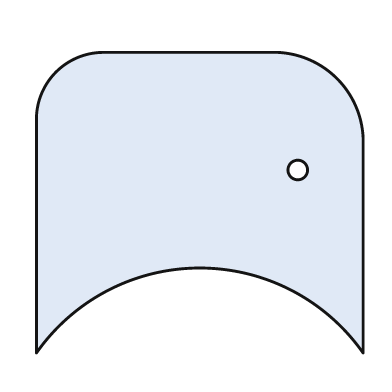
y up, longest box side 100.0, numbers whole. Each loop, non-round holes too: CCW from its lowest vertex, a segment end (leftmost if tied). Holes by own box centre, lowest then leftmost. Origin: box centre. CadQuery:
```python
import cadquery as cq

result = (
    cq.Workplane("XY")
    .moveTo(-50.0, -46.0)
    .threePointArc((0.0, -20.0), (50.0, -46.0))
    .lineTo(50.0, 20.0)
    .threePointArc((42.0, 38.0), (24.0, 46.0))
    .lineTo(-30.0, 46.0)
    .threePointArc((-44.0, 40.0), (-50.0, 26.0))
    .close()
    .moveTo(30.0, 10.0)
    .circle(3.0)
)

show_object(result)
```